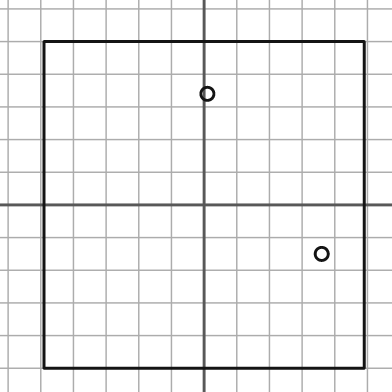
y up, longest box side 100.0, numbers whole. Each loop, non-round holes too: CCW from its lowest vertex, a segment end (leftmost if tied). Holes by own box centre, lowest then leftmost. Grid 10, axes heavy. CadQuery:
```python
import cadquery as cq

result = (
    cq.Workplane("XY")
    .moveTo(-49.0, -50.0)
    .lineTo(49.0, -50.0)
    .lineTo(49.0, 50.0)
    .lineTo(-49.0, 50.0)
    .close()
    .moveTo(36.0, -15.0)
    .circle(2.0)
    .moveTo(1.0, 34.0)
    .circle(2.0)
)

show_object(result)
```